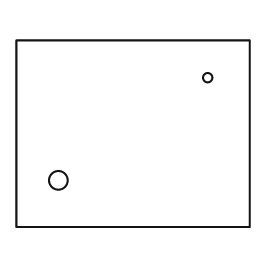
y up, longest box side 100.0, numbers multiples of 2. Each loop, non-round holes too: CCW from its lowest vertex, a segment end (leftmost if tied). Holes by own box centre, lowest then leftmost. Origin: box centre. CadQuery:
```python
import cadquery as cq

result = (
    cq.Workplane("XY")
    .moveTo(-50.0, -40.0)
    .lineTo(50.0, -40.0)
    .lineTo(50.0, 40.0)
    .lineTo(-50.0, 40.0)
    .close()
    .moveTo(-32.0, -20.0)
    .circle(4.0)
    .moveTo(32.0, 24.0)
    .circle(2.0)
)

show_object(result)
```